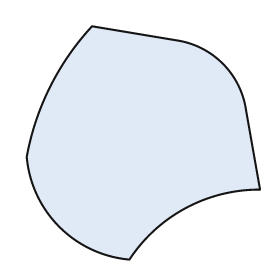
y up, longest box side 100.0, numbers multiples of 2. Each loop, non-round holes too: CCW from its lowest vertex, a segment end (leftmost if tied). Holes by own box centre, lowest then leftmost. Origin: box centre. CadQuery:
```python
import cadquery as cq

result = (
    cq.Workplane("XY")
    .moveTo(-6.0, -50.0)
    .threePointArc((18.0, -28.0), (50.0, -20.0))
    .lineTo(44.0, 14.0)
    .threePointArc((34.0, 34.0), (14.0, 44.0))
    .lineTo(-22.0, 50.0)
    .threePointArc((-40.0, 24.0), (-50.0, -6.0))
    .threePointArc((-36.0, -36.0), (-6.0, -50.0))
    .close()
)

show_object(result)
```